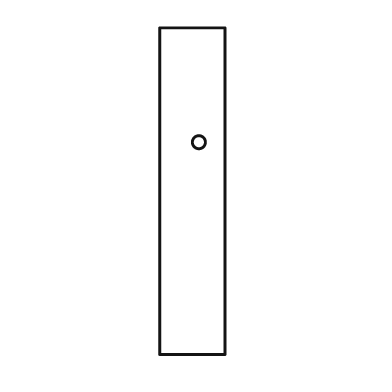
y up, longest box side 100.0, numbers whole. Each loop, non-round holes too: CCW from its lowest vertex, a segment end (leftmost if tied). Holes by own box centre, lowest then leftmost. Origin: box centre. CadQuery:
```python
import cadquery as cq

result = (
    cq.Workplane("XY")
    .moveTo(-10.0, -50.0)
    .lineTo(10.0, -50.0)
    .lineTo(10.0, 50.0)
    .lineTo(-10.0, 50.0)
    .close()
    .moveTo(2.0, 15.0)
    .circle(2.0)
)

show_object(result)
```